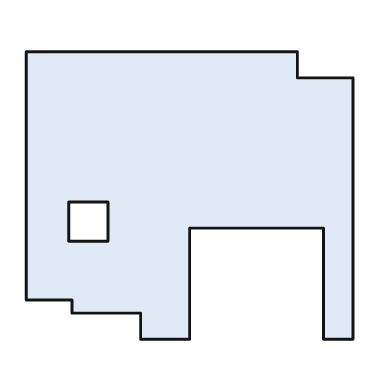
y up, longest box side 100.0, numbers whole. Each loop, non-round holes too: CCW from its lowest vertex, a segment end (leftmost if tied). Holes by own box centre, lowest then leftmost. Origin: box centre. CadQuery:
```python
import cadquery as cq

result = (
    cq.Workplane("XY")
    .moveTo(-15.0, -44.0)
    .lineTo(0.0, -44.0)
    .lineTo(0.0, -10.0)
    .lineTo(41.0, -10.0)
    .lineTo(41.0, -44.0)
    .lineTo(50.0, -44.0)
    .lineTo(50.0, 36.0)
    .lineTo(33.0, 36.0)
    .lineTo(33.0, 44.0)
    .lineTo(-50.0, 44.0)
    .lineTo(-50.0, -32.0)
    .lineTo(-36.0, -32.0)
    .lineTo(-36.0, -36.0)
    .lineTo(-15.0, -36.0)
    .close()
    .moveTo(-37.0, -14.0)
    .lineTo(-25.0, -14.0)
    .lineTo(-25.0, -2.0)
    .lineTo(-37.0, -2.0)
    .close()
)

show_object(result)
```